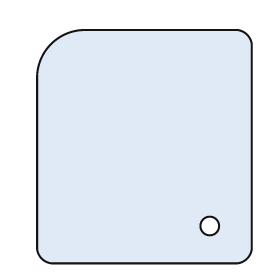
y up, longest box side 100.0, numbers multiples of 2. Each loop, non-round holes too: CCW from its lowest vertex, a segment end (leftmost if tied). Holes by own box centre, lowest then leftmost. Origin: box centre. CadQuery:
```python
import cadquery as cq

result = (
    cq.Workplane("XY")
    .moveTo(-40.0, -50.0)
    .lineTo(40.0, -50.0)
    .threePointArc((44.0, -48.0), (46.0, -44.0))
    .lineTo(46.0, 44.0)
    .threePointArc((44.0, 48.0), (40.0, 50.0))
    .lineTo(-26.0, 50.0)
    .threePointArc((-40.0, 44.0), (-46.0, 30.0))
    .lineTo(-46.0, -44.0)
    .threePointArc((-44.0, -48.0), (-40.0, -50.0))
    .close()
    .moveTo(28.0, -34.0)
    .circle(4.0)
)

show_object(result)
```